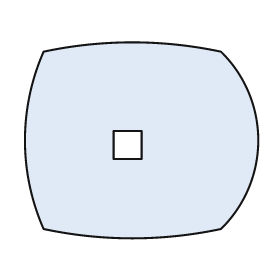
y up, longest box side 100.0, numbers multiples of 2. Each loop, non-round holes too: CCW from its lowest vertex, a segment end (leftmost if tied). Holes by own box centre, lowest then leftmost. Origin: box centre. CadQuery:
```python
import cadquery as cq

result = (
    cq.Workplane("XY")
    .moveTo(-42.0, -38.0)
    .threePointArc((-4.0, -42.0), (34.0, -38.0))
    .threePointArc((50.0, 0.0), (34.0, 38.0))
    .threePointArc((-4.0, 42.0), (-42.0, 38.0))
    .threePointArc((-50.0, 0.0), (-42.0, -38.0))
    .close()
    .moveTo(-12.0, -8.0)
    .lineTo(0.0, -8.0)
    .lineTo(0.0, 4.0)
    .lineTo(-12.0, 4.0)
    .close()
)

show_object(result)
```